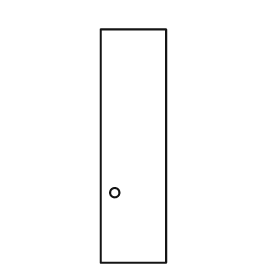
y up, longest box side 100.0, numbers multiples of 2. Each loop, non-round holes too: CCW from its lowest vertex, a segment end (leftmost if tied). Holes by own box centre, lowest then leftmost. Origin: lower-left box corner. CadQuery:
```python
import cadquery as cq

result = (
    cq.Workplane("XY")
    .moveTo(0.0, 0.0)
    .lineTo(28.0, 0.0)
    .lineTo(28.0, 100.0)
    .lineTo(0.0, 100.0)
    .close()
    .moveTo(6.0, 30.0)
    .circle(2.0)
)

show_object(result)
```